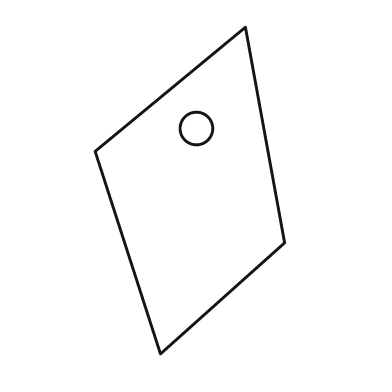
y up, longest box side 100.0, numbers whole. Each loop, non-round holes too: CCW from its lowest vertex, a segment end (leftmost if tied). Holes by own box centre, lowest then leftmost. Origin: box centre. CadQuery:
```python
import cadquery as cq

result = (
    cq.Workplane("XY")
    .moveTo(-9.0, -50.0)
    .lineTo(29.0, -16.0)
    .lineTo(17.0, 50.0)
    .lineTo(-29.0, 12.0)
    .close()
    .moveTo(2.0, 19.0)
    .circle(5.0)
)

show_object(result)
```